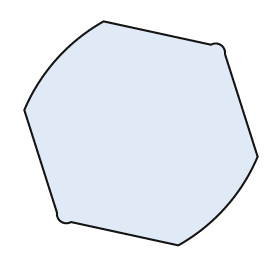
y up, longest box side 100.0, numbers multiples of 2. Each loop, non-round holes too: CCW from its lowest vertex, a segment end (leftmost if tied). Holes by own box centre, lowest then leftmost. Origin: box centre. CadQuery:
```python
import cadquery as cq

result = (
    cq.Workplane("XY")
    .moveTo(16.0, -48.0)
    .threePointArc((36.0, -32.0), (50.0, -10.0))
    .lineTo(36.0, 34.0)
    .threePointArc((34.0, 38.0), (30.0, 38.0))
    .lineTo(-16.0, 48.0)
    .threePointArc((-36.0, 32.0), (-50.0, 10.0))
    .lineTo(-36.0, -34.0)
    .threePointArc((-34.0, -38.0), (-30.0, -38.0))
    .close()
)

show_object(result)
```